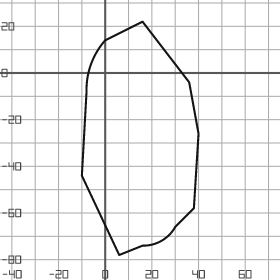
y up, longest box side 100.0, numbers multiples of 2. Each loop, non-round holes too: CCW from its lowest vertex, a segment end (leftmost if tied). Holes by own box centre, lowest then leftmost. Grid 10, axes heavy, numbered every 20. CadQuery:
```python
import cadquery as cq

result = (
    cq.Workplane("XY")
    .moveTo(6.0, -78.0)
    .lineTo(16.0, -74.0)
    .threePointArc((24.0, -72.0), (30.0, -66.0))
    .lineTo(38.0, -58.0)
    .lineTo(40.0, -26.0)
    .lineTo(36.0, -4.0)
    .lineTo(16.0, 22.0)
    .lineTo(0.0, 14.0)
    .threePointArc((-6.0, 4.0), (-8.0, -8.0))
    .lineTo(-10.0, -44.0)
    .close()
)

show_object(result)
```